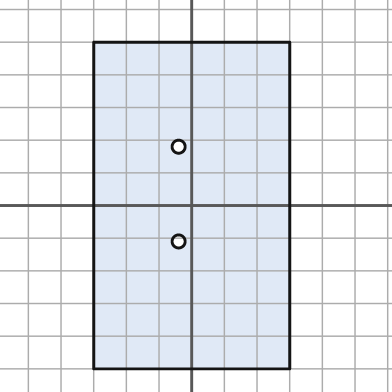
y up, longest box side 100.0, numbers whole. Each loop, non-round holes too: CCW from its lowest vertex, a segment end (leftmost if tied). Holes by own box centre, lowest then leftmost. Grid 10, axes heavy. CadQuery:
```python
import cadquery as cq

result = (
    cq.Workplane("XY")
    .moveTo(-30.0, -50.0)
    .lineTo(30.0, -50.0)
    .lineTo(30.0, 50.0)
    .lineTo(-30.0, 50.0)
    .close()
    .moveTo(-4.0, -11.0)
    .circle(2.0)
    .moveTo(-4.0, 18.0)
    .circle(2.0)
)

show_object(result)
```